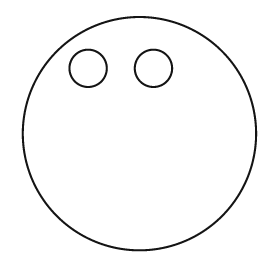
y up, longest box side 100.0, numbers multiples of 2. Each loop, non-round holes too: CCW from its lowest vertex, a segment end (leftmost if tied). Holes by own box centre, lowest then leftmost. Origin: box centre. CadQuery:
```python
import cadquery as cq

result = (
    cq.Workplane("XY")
    .moveTo(0.0, 0.0)
    .circle(50.0)
    .moveTo(-22.0, 28.0)
    .circle(8.0)
    .moveTo(6.0, 28.0)
    .circle(8.0)
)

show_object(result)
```